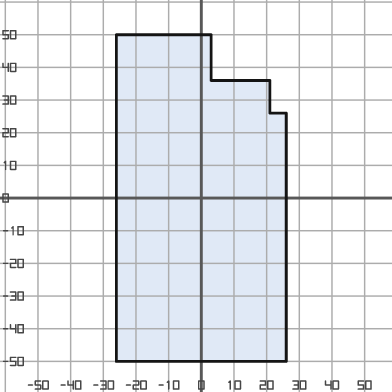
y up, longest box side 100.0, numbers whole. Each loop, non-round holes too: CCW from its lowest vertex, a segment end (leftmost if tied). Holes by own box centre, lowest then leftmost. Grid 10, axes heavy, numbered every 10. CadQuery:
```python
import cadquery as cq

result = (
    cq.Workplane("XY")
    .moveTo(-26.0, -50.0)
    .lineTo(26.0, -50.0)
    .lineTo(26.0, 26.0)
    .lineTo(21.0, 26.0)
    .lineTo(21.0, 36.0)
    .lineTo(3.0, 36.0)
    .lineTo(3.0, 50.0)
    .lineTo(-26.0, 50.0)
    .close()
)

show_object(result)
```